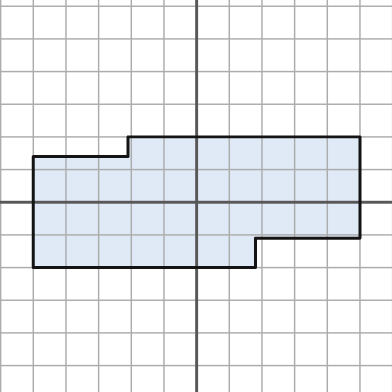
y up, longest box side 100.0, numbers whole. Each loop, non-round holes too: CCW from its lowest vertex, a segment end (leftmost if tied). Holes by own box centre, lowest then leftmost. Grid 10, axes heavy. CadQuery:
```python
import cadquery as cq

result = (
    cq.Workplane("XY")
    .moveTo(-50.0, -20.0)
    .lineTo(18.0, -20.0)
    .lineTo(18.0, -11.0)
    .lineTo(50.0, -11.0)
    .lineTo(50.0, 20.0)
    .lineTo(-21.0, 20.0)
    .lineTo(-21.0, 14.0)
    .lineTo(-50.0, 14.0)
    .close()
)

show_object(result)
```